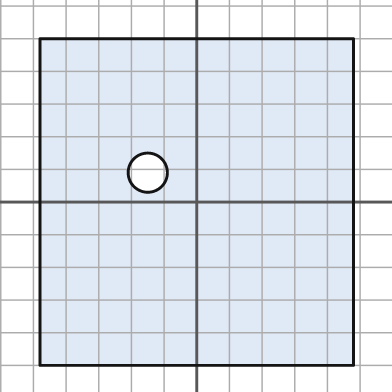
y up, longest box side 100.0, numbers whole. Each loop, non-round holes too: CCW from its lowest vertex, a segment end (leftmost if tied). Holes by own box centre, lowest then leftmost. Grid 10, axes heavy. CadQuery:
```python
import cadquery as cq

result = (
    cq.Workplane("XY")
    .moveTo(-48.0, -50.0)
    .lineTo(48.0, -50.0)
    .lineTo(48.0, 50.0)
    .lineTo(-48.0, 50.0)
    .close()
    .moveTo(-15.0, 9.0)
    .circle(6.0)
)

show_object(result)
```